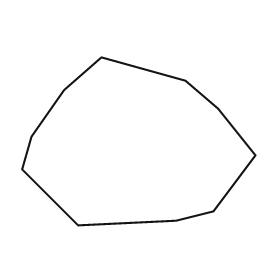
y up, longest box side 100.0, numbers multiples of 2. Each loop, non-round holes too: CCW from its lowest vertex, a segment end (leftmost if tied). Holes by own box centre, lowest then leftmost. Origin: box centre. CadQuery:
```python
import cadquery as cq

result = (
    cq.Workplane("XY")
    .moveTo(-26.0, -36.0)
    .lineTo(16.0, -34.0)
    .lineTo(32.0, -30.0)
    .lineTo(50.0, -6.0)
    .lineTo(34.0, 14.0)
    .lineTo(20.0, 26.0)
    .lineTo(-16.0, 36.0)
    .lineTo(-32.0, 22.0)
    .lineTo(-46.0, 2.0)
    .lineTo(-50.0, -12.0)
    .close()
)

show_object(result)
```